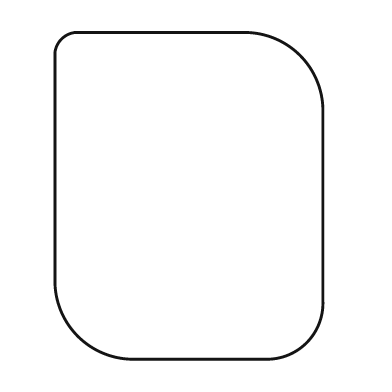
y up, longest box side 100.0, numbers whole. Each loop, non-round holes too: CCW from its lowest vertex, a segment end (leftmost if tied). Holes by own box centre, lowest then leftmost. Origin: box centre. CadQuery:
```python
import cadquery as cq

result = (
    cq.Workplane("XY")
    .moveTo(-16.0, -50.0)
    .lineTo(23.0, -50.0)
    .threePointArc((36.0, -45.0), (41.0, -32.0))
    .lineTo(41.0, 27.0)
    .threePointArc((34.0, 43.0), (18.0, 50.0))
    .lineTo(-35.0, 50.0)
    .threePointArc((-39.0, 48.0), (-41.0, 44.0))
    .lineTo(-41.0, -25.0)
    .threePointArc((-34.0, -43.0), (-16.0, -50.0))
    .close()
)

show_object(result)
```